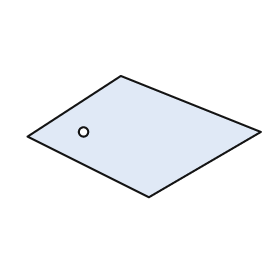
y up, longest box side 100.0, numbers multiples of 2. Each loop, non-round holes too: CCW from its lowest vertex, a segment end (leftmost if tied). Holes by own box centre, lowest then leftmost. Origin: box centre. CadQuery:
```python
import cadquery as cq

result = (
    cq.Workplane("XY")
    .moveTo(2.0, -26.0)
    .lineTo(50.0, 2.0)
    .lineTo(-10.0, 26.0)
    .lineTo(-50.0, 0.0)
    .close()
    .moveTo(-26.0, 2.0)
    .circle(2.0)
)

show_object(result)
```